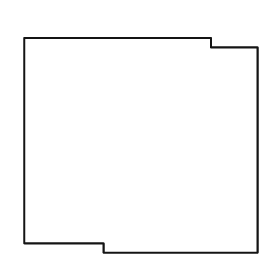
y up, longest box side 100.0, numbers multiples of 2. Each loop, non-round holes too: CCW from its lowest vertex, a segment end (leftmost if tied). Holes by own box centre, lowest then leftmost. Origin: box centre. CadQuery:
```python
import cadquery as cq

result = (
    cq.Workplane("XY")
    .moveTo(-16.0, -46.0)
    .lineTo(50.0, -46.0)
    .lineTo(50.0, 42.0)
    .lineTo(30.0, 42.0)
    .lineTo(30.0, 46.0)
    .lineTo(-50.0, 46.0)
    .lineTo(-50.0, -42.0)
    .lineTo(-16.0, -42.0)
    .close()
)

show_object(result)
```